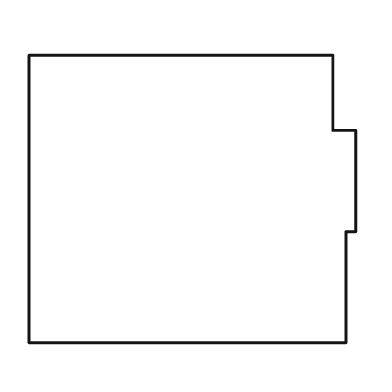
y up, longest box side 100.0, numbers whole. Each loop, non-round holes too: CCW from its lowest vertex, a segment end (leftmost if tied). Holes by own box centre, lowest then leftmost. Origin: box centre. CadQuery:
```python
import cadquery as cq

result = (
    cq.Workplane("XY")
    .moveTo(-50.0, -44.0)
    .lineTo(47.0, -44.0)
    .lineTo(47.0, -10.0)
    .lineTo(50.0, -10.0)
    .lineTo(50.0, 21.0)
    .lineTo(43.0, 21.0)
    .lineTo(43.0, 44.0)
    .lineTo(-50.0, 44.0)
    .close()
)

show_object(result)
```